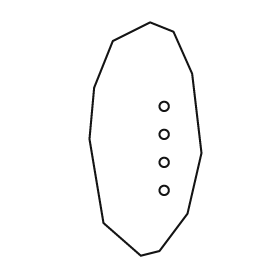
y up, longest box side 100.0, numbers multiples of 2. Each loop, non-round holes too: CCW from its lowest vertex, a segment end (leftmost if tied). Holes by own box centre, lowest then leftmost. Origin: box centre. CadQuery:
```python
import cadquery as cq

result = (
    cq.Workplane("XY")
    .moveTo(-2.0, -50.0)
    .lineTo(6.0, -48.0)
    .lineTo(18.0, -32.0)
    .lineTo(24.0, -6.0)
    .lineTo(20.0, 28.0)
    .lineTo(12.0, 46.0)
    .lineTo(2.0, 50.0)
    .lineTo(-14.0, 42.0)
    .lineTo(-22.0, 22.0)
    .lineTo(-24.0, 0.0)
    .lineTo(-18.0, -36.0)
    .close()
    .moveTo(8.0, -22.0)
    .circle(2.0)
    .moveTo(8.0, -10.0)
    .circle(2.0)
    .moveTo(8.0, 2.0)
    .circle(2.0)
    .moveTo(8.0, 14.0)
    .circle(2.0)
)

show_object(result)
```